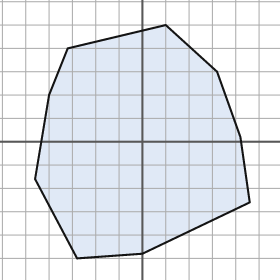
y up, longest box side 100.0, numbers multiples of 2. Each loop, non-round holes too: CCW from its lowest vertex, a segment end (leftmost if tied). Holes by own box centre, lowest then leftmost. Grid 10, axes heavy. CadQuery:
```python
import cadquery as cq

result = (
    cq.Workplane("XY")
    .moveTo(-28.0, -50.0)
    .lineTo(0.0, -48.0)
    .lineTo(46.0, -26.0)
    .lineTo(42.0, 2.0)
    .lineTo(32.0, 30.0)
    .lineTo(10.0, 50.0)
    .lineTo(-32.0, 40.0)
    .lineTo(-40.0, 20.0)
    .lineTo(-46.0, -16.0)
    .close()
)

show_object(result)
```